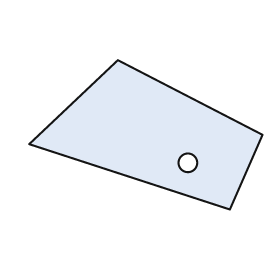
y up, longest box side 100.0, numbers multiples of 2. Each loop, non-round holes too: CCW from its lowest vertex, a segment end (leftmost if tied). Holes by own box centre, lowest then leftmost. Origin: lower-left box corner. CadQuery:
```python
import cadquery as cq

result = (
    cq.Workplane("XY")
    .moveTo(86.0, 0.0)
    .lineTo(100.0, 32.0)
    .lineTo(38.0, 64.0)
    .lineTo(0.0, 28.0)
    .close()
    .moveTo(68.0, 20.0)
    .circle(4.0)
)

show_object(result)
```